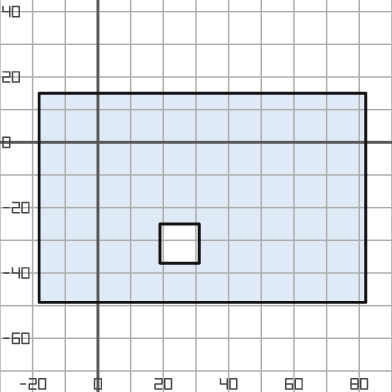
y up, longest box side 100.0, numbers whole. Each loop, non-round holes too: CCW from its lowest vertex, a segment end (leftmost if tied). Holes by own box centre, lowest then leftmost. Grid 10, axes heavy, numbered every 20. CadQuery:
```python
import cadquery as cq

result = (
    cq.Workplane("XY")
    .moveTo(-18.0, -49.0)
    .lineTo(82.0, -49.0)
    .lineTo(82.0, 15.0)
    .lineTo(-18.0, 15.0)
    .close()
    .moveTo(19.0, -37.0)
    .lineTo(31.0, -37.0)
    .lineTo(31.0, -25.0)
    .lineTo(19.0, -25.0)
    .close()
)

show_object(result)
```